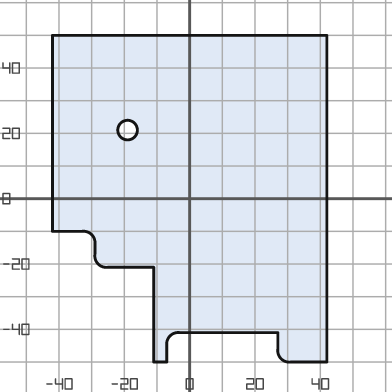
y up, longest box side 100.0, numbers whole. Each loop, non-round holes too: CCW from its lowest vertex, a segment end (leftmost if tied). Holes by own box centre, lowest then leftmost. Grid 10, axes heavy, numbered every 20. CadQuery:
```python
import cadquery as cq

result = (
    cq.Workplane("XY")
    .moveTo(-11.0, -50.0)
    .lineTo(-7.0, -50.0)
    .lineTo(-7.0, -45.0)
    .threePointArc((-6.0, -42.0), (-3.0, -41.0))
    .lineTo(27.0, -41.0)
    .lineTo(27.0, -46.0)
    .threePointArc((28.0, -49.0), (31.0, -50.0))
    .lineTo(42.0, -50.0)
    .lineTo(42.0, 50.0)
    .lineTo(-42.0, 50.0)
    .lineTo(-42.0, -10.0)
    .lineTo(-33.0, -10.0)
    .threePointArc((-30.0, -11.0), (-29.0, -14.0))
    .lineTo(-29.0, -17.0)
    .threePointArc((-28.0, -20.0), (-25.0, -21.0))
    .lineTo(-11.0, -21.0)
    .close()
    .moveTo(-19.0, 21.0)
    .circle(3.0)
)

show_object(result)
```